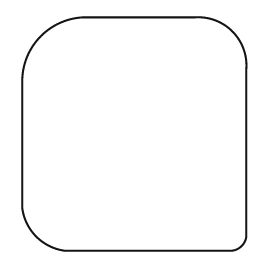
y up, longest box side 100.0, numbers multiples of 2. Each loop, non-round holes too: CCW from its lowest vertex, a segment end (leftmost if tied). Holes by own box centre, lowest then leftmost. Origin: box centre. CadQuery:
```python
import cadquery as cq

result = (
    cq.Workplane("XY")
    .moveTo(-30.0, -50.0)
    .lineTo(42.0, -50.0)
    .threePointArc((46.0, -48.0), (48.0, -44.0))
    .lineTo(48.0, 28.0)
    .threePointArc((42.0, 44.0), (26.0, 50.0))
    .lineTo(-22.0, 50.0)
    .threePointArc((-40.0, 42.0), (-48.0, 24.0))
    .lineTo(-48.0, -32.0)
    .threePointArc((-42.0, -44.0), (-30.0, -50.0))
    .close()
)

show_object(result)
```